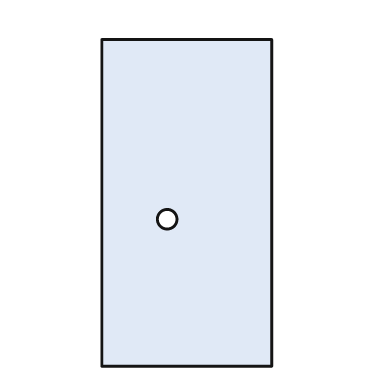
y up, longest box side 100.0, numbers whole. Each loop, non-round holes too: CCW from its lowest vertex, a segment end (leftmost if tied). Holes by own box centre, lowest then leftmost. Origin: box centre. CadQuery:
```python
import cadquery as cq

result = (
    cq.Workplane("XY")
    .moveTo(-26.0, -50.0)
    .lineTo(26.0, -50.0)
    .lineTo(26.0, 50.0)
    .lineTo(-26.0, 50.0)
    .close()
    .moveTo(-6.0, -5.0)
    .circle(3.0)
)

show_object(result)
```